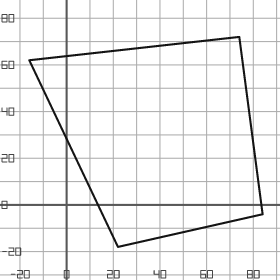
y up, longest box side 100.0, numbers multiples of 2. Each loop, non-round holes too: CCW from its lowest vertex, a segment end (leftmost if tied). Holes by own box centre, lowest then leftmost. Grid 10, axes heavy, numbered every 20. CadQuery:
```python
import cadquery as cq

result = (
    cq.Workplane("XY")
    .moveTo(22.0, -18.0)
    .lineTo(84.0, -4.0)
    .lineTo(74.0, 72.0)
    .lineTo(-16.0, 62.0)
    .close()
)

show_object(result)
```